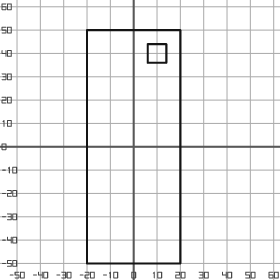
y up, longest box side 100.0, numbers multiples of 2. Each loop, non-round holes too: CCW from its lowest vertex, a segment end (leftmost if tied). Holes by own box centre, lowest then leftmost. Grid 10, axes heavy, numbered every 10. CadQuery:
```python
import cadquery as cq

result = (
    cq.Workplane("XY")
    .moveTo(-20.0, -50.0)
    .lineTo(20.0, -50.0)
    .lineTo(20.0, 50.0)
    .lineTo(-20.0, 50.0)
    .close()
    .moveTo(6.0, 36.0)
    .lineTo(14.0, 36.0)
    .lineTo(14.0, 44.0)
    .lineTo(6.0, 44.0)
    .close()
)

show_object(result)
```